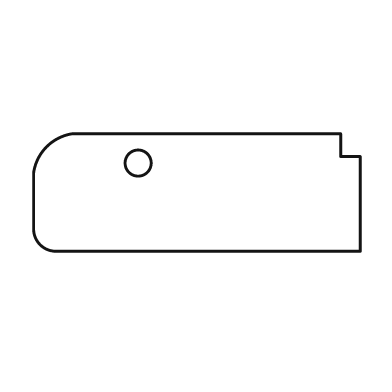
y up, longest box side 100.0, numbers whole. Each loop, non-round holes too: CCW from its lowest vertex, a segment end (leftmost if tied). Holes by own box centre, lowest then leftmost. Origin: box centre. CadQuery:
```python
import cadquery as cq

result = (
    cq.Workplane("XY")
    .moveTo(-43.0, -18.0)
    .lineTo(50.0, -18.0)
    .lineTo(50.0, 11.0)
    .lineTo(44.0, 11.0)
    .lineTo(44.0, 18.0)
    .lineTo(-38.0, 18.0)
    .threePointArc((-46.0, 14.0), (-50.0, 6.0))
    .lineTo(-50.0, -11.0)
    .threePointArc((-48.0, -16.0), (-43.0, -18.0))
    .close()
    .moveTo(-18.0, 9.0)
    .circle(4.0)
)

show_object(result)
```